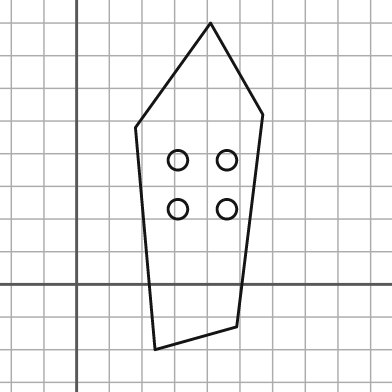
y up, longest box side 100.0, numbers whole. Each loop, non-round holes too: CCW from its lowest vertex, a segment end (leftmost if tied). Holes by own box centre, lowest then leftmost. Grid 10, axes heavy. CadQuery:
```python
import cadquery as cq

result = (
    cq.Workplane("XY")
    .moveTo(24.0, -20.0)
    .lineTo(49.0, -13.0)
    .lineTo(57.0, 52.0)
    .lineTo(41.0, 80.0)
    .lineTo(18.0, 48.0)
    .close()
    .moveTo(31.0, 23.0)
    .circle(3.0)
    .moveTo(46.0, 23.0)
    .circle(3.0)
    .moveTo(31.0, 38.0)
    .circle(3.0)
    .moveTo(46.0, 38.0)
    .circle(3.0)
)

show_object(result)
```